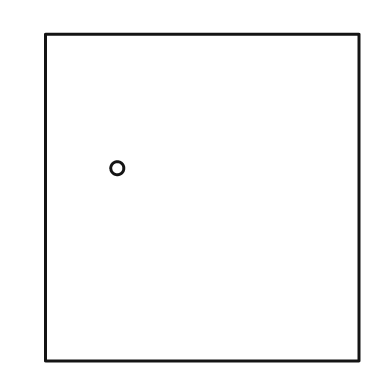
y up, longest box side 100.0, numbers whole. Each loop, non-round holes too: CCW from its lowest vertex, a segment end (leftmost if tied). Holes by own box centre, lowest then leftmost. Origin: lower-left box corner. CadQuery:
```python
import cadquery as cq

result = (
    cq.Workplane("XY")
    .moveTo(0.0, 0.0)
    .lineTo(96.0, 0.0)
    .lineTo(96.0, 100.0)
    .lineTo(0.0, 100.0)
    .close()
    .moveTo(22.0, 59.0)
    .circle(2.0)
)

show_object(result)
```